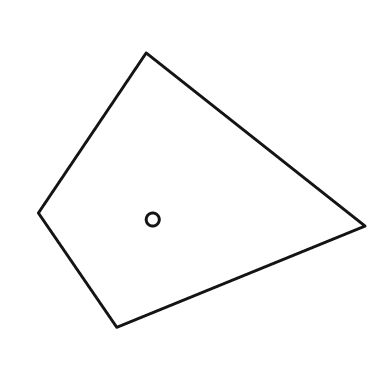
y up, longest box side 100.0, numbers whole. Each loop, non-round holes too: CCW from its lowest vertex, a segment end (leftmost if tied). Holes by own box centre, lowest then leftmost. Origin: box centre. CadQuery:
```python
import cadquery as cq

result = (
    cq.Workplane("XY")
    .moveTo(-26.0, -42.0)
    .lineTo(50.0, -11.0)
    .lineTo(-17.0, 42.0)
    .lineTo(-50.0, -7.0)
    .close()
    .moveTo(-15.0, -9.0)
    .circle(2.0)
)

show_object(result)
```